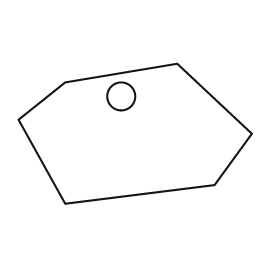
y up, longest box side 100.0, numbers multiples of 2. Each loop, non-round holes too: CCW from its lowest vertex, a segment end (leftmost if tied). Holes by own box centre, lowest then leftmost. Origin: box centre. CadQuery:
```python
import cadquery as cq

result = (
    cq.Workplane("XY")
    .moveTo(-30.0, -30.0)
    .lineTo(34.0, -22.0)
    .lineTo(50.0, 0.0)
    .lineTo(18.0, 30.0)
    .lineTo(-30.0, 22.0)
    .lineTo(-50.0, 6.0)
    .close()
    .moveTo(-6.0, 16.0)
    .circle(6.0)
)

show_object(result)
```